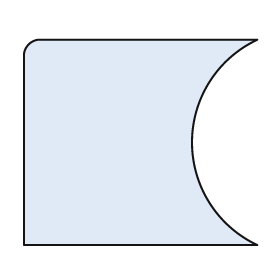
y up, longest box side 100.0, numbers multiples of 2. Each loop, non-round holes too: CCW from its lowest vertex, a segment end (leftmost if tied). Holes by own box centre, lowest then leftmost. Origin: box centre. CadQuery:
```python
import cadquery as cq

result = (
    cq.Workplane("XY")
    .moveTo(-50.0, -44.0)
    .lineTo(50.0, -44.0)
    .threePointArc((22.0, 0.0), (50.0, 44.0))
    .lineTo(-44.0, 44.0)
    .threePointArc((-48.0, 42.0), (-50.0, 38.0))
    .close()
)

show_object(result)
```